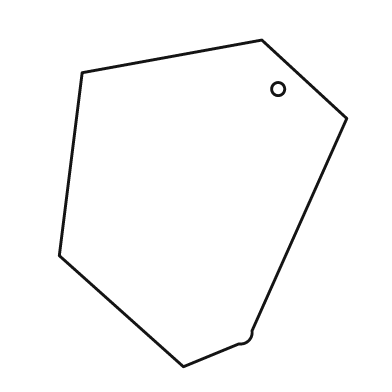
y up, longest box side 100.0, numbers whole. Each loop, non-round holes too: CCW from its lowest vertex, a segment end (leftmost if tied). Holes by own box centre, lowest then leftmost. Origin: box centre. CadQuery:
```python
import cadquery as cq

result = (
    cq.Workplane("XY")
    .moveTo(-6.0, -50.0)
    .lineTo(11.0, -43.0)
    .threePointArc((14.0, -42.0), (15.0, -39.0))
    .lineTo(44.0, 26.0)
    .lineTo(18.0, 50.0)
    .lineTo(-37.0, 40.0)
    .lineTo(-44.0, -16.0)
    .close()
    .moveTo(23.0, 35.0)
    .circle(2.0)
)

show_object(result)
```